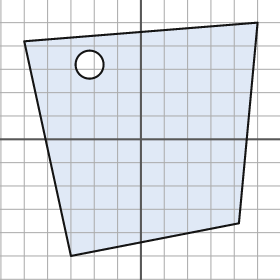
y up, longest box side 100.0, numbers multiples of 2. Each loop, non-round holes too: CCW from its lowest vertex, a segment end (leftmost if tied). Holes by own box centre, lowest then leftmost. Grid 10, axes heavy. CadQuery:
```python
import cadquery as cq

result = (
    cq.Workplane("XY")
    .moveTo(-30.0, -50.0)
    .lineTo(42.0, -36.0)
    .lineTo(50.0, 50.0)
    .lineTo(-50.0, 42.0)
    .close()
    .moveTo(-22.0, 32.0)
    .circle(6.0)
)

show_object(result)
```